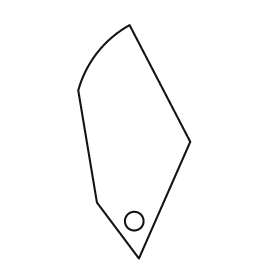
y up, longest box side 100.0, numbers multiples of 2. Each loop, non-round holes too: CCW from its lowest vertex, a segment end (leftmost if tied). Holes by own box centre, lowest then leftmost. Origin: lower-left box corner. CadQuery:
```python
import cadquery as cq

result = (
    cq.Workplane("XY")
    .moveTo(26.0, 0.0)
    .lineTo(48.0, 50.0)
    .lineTo(22.0, 100.0)
    .threePointArc((8.0, 88.0), (0.0, 72.0))
    .lineTo(8.0, 24.0)
    .close()
    .moveTo(24.0, 16.0)
    .circle(4.0)
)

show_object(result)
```